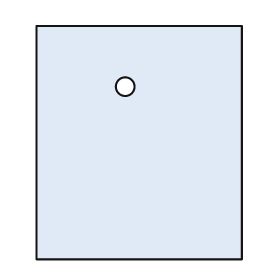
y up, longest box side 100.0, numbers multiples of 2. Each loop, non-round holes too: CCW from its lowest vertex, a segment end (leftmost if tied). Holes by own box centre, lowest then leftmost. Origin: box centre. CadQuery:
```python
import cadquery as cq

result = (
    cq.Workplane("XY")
    .moveTo(-44.0, -50.0)
    .lineTo(44.0, -50.0)
    .lineTo(44.0, 50.0)
    .lineTo(-44.0, 50.0)
    .close()
    .moveTo(-6.0, 24.0)
    .circle(4.0)
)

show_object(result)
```